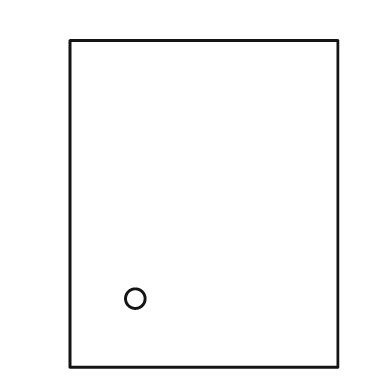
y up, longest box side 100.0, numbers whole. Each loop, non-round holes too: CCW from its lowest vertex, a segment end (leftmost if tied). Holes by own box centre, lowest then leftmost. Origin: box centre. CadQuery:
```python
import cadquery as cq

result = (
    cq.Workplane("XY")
    .moveTo(-41.0, -50.0)
    .lineTo(41.0, -50.0)
    .lineTo(41.0, 50.0)
    .lineTo(-41.0, 50.0)
    .close()
    .moveTo(-21.0, -29.0)
    .circle(3.0)
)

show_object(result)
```